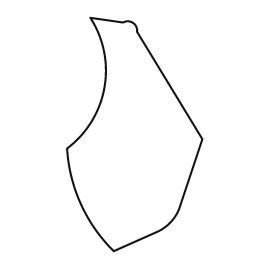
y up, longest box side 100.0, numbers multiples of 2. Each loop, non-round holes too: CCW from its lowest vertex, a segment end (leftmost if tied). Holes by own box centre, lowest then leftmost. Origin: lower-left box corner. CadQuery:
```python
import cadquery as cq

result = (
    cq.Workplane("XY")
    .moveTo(20.0, 0.0)
    .lineTo(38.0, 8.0)
    .threePointArc((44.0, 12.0), (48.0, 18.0))
    .lineTo(58.0, 48.0)
    .lineTo(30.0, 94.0)
    .threePointArc((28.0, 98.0), (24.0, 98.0))
    .lineTo(10.0, 100.0)
    .threePointArc((16.0, 70.0), (0.0, 44.0))
    .threePointArc((6.0, 20.0), (20.0, 0.0))
    .close()
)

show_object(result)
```